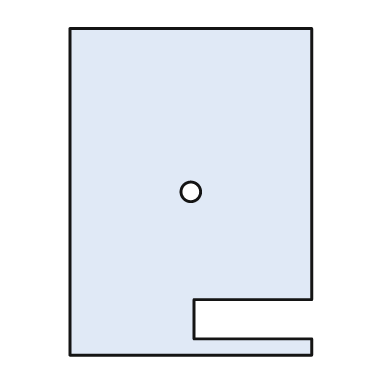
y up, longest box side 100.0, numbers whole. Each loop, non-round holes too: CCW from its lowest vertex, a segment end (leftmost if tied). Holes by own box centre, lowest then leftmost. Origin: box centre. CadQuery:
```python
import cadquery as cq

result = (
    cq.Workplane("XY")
    .moveTo(-37.0, -50.0)
    .lineTo(37.0, -50.0)
    .lineTo(37.0, -45.0)
    .lineTo(1.0, -45.0)
    .lineTo(1.0, -33.0)
    .lineTo(37.0, -33.0)
    .lineTo(37.0, 50.0)
    .lineTo(-37.0, 50.0)
    .close()
    .moveTo(0.0, 0.0)
    .circle(3.0)
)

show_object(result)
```